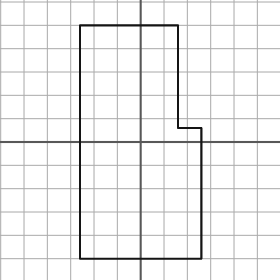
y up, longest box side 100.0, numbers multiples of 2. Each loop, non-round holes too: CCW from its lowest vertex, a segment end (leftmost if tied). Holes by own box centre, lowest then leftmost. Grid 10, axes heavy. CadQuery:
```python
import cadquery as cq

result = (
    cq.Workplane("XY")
    .moveTo(-26.0, -50.0)
    .lineTo(26.0, -50.0)
    .lineTo(26.0, 6.0)
    .lineTo(16.0, 6.0)
    .lineTo(16.0, 50.0)
    .lineTo(-26.0, 50.0)
    .close()
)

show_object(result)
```